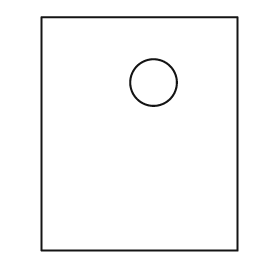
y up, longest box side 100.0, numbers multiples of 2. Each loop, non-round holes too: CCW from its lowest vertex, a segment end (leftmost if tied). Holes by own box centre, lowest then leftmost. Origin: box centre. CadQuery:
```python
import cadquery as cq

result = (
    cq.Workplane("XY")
    .moveTo(-42.0, -50.0)
    .lineTo(42.0, -50.0)
    .lineTo(42.0, 50.0)
    .lineTo(-42.0, 50.0)
    .close()
    .moveTo(6.0, 22.0)
    .circle(10.0)
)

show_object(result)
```